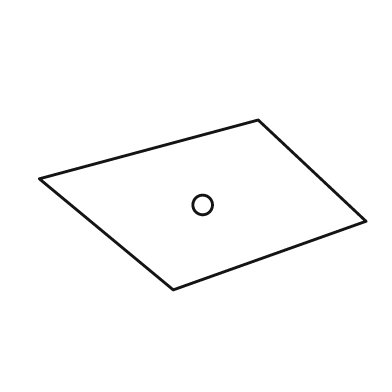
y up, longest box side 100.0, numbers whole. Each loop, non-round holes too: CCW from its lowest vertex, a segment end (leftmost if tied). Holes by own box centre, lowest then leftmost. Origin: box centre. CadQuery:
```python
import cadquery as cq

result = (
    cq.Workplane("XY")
    .moveTo(-9.0, -26.0)
    .lineTo(50.0, -5.0)
    .lineTo(17.0, 26.0)
    .lineTo(-50.0, 8.0)
    .close()
    .moveTo(0.0, 0.0)
    .circle(3.0)
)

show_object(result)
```